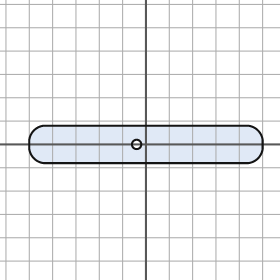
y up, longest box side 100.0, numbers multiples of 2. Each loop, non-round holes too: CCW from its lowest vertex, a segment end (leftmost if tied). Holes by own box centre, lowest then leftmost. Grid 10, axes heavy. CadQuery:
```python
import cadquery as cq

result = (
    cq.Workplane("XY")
    .moveTo(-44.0, -8.0)
    .lineTo(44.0, -8.0)
    .threePointArc((48.0, -6.0), (50.0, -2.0))
    .lineTo(50.0, 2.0)
    .threePointArc((48.0, 6.0), (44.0, 8.0))
    .lineTo(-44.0, 8.0)
    .threePointArc((-48.0, 6.0), (-50.0, 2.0))
    .lineTo(-50.0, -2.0)
    .threePointArc((-48.0, -6.0), (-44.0, -8.0))
    .close()
    .moveTo(-4.0, 0.0)
    .circle(2.0)
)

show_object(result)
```